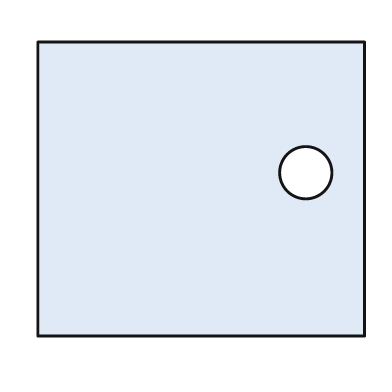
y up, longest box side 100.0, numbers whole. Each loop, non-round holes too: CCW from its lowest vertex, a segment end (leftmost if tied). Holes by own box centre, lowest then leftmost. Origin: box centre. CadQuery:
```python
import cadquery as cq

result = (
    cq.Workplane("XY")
    .moveTo(-50.0, -45.0)
    .lineTo(50.0, -45.0)
    .lineTo(50.0, 45.0)
    .lineTo(-50.0, 45.0)
    .close()
    .moveTo(32.0, 5.0)
    .circle(8.0)
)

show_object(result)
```